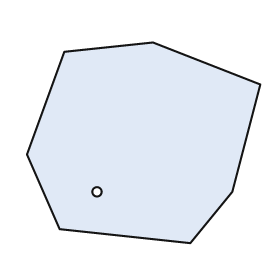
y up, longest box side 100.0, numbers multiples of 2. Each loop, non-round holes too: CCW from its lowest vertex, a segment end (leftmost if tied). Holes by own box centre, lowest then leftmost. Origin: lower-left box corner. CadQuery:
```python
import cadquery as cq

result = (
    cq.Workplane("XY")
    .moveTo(70.0, 0.0)
    .lineTo(88.0, 22.0)
    .lineTo(100.0, 68.0)
    .lineTo(54.0, 86.0)
    .lineTo(16.0, 82.0)
    .lineTo(0.0, 38.0)
    .lineTo(14.0, 6.0)
    .close()
    .moveTo(30.0, 22.0)
    .circle(2.0)
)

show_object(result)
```